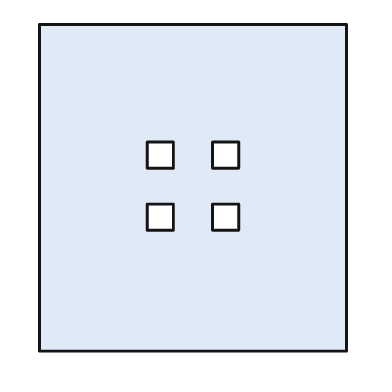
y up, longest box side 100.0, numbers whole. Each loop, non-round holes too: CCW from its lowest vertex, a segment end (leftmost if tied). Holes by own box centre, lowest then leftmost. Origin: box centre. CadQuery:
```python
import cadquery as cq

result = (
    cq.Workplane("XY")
    .moveTo(-47.0, -50.0)
    .lineTo(47.0, -50.0)
    .lineTo(47.0, 50.0)
    .lineTo(-47.0, 50.0)
    .close()
    .moveTo(-14.0, -13.0)
    .lineTo(-6.0, -13.0)
    .lineTo(-6.0, -5.0)
    .lineTo(-14.0, -5.0)
    .close()
    .moveTo(6.0, -13.0)
    .lineTo(14.0, -13.0)
    .lineTo(14.0, -5.0)
    .lineTo(6.0, -5.0)
    .close()
    .moveTo(-14.0, 6.0)
    .lineTo(-6.0, 6.0)
    .lineTo(-6.0, 14.0)
    .lineTo(-14.0, 14.0)
    .close()
    .moveTo(6.0, 6.0)
    .lineTo(14.0, 6.0)
    .lineTo(14.0, 14.0)
    .lineTo(6.0, 14.0)
    .close()
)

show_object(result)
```